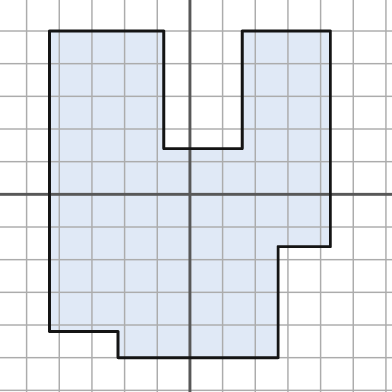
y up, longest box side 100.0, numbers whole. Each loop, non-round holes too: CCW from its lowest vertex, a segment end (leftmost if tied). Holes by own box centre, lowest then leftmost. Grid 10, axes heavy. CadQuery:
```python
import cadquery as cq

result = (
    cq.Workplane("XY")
    .moveTo(-22.0, -50.0)
    .lineTo(27.0, -50.0)
    .lineTo(27.0, -16.0)
    .lineTo(43.0, -16.0)
    .lineTo(43.0, 50.0)
    .lineTo(16.0, 50.0)
    .lineTo(16.0, 14.0)
    .lineTo(-8.0, 14.0)
    .lineTo(-8.0, 50.0)
    .lineTo(-43.0, 50.0)
    .lineTo(-43.0, -42.0)
    .lineTo(-22.0, -42.0)
    .close()
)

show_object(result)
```